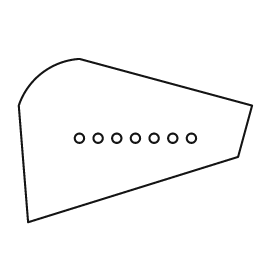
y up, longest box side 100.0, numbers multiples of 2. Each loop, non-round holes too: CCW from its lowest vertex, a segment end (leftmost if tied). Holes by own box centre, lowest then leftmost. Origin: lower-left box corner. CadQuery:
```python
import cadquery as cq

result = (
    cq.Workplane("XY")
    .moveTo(4.0, 0.0)
    .lineTo(94.0, 28.0)
    .lineTo(100.0, 50.0)
    .lineTo(26.0, 70.0)
    .threePointArc((10.0, 64.0), (0.0, 50.0))
    .close()
    .moveTo(26.0, 36.0)
    .circle(2.0)
    .moveTo(34.0, 36.0)
    .circle(2.0)
    .moveTo(42.0, 36.0)
    .circle(2.0)
    .moveTo(50.0, 36.0)
    .circle(2.0)
    .moveTo(58.0, 36.0)
    .circle(2.0)
    .moveTo(66.0, 36.0)
    .circle(2.0)
    .moveTo(74.0, 36.0)
    .circle(2.0)
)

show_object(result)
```